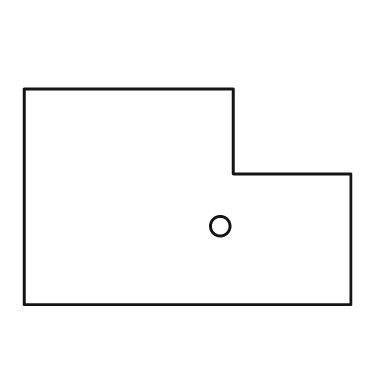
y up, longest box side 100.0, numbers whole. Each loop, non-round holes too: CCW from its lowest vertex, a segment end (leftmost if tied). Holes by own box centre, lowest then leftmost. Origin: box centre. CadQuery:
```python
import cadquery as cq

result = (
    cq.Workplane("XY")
    .moveTo(-50.0, -33.0)
    .lineTo(50.0, -33.0)
    .lineTo(50.0, 7.0)
    .lineTo(14.0, 7.0)
    .lineTo(14.0, 33.0)
    .lineTo(-50.0, 33.0)
    .close()
    .moveTo(10.0, -9.0)
    .circle(3.0)
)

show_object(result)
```